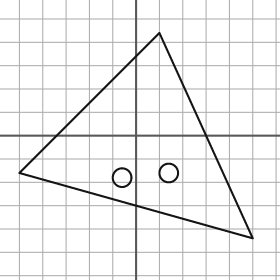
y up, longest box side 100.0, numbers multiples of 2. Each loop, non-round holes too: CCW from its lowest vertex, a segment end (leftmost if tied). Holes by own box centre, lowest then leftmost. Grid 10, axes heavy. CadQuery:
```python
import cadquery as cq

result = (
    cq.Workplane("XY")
    .moveTo(50.0, -44.0)
    .lineTo(10.0, 44.0)
    .lineTo(-50.0, -16.0)
    .close()
    .moveTo(-6.0, -18.0)
    .circle(4.0)
    .moveTo(14.0, -16.0)
    .circle(4.0)
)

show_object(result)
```